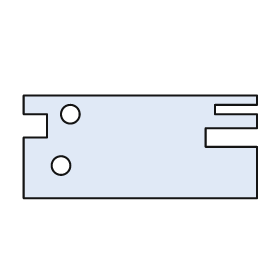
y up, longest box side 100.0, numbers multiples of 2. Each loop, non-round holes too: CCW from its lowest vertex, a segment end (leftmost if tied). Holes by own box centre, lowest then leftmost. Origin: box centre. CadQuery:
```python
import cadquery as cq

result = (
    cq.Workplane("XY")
    .moveTo(-50.0, -22.0)
    .lineTo(50.0, -22.0)
    .lineTo(50.0, 0.0)
    .lineTo(28.0, 0.0)
    .lineTo(28.0, 8.0)
    .lineTo(50.0, 8.0)
    .lineTo(50.0, 14.0)
    .lineTo(32.0, 14.0)
    .lineTo(32.0, 18.0)
    .lineTo(50.0, 18.0)
    .lineTo(50.0, 22.0)
    .lineTo(-50.0, 22.0)
    .lineTo(-50.0, 14.0)
    .lineTo(-40.0, 14.0)
    .lineTo(-40.0, 4.0)
    .lineTo(-50.0, 4.0)
    .close()
    .moveTo(-34.0, -8.0)
    .circle(4.0)
    .moveTo(-30.0, 14.0)
    .circle(4.0)
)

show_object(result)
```